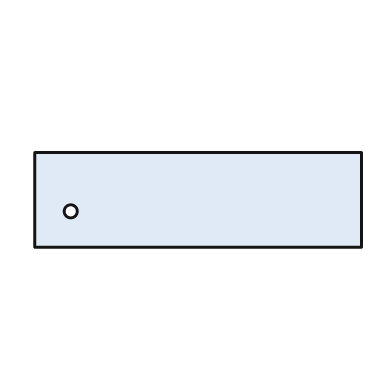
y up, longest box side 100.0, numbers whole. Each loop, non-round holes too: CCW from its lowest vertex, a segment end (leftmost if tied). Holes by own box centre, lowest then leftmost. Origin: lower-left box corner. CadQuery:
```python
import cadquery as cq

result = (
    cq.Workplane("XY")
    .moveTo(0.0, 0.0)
    .lineTo(100.0, 0.0)
    .lineTo(100.0, 29.0)
    .lineTo(0.0, 29.0)
    .close()
    .moveTo(11.0, 11.0)
    .circle(2.0)
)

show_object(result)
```